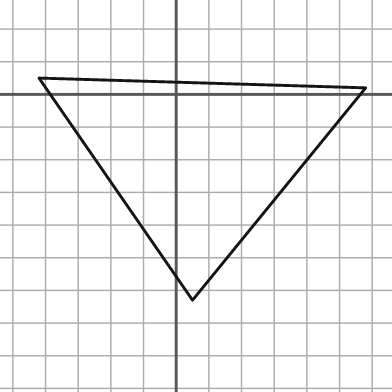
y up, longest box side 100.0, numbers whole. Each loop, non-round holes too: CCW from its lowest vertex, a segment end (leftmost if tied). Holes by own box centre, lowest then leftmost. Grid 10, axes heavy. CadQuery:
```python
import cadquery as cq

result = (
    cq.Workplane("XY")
    .moveTo(5.0, -63.0)
    .lineTo(58.0, 2.0)
    .lineTo(-42.0, 5.0)
    .close()
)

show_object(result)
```